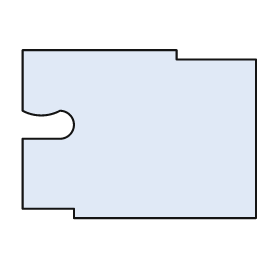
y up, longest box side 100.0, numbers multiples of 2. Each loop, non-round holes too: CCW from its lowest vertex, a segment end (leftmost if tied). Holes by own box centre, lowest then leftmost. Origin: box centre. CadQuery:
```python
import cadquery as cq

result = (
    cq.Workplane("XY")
    .moveTo(-28.0, -36.0)
    .lineTo(50.0, -36.0)
    .lineTo(50.0, 32.0)
    .lineTo(16.0, 32.0)
    .lineTo(16.0, 36.0)
    .lineTo(-50.0, 36.0)
    .lineTo(-50.0, 10.0)
    .threePointArc((-42.0, 8.0), (-34.0, 10.0))
    .threePointArc((-28.0, 4.0), (-34.0, -2.0))
    .lineTo(-50.0, -2.0)
    .lineTo(-50.0, -32.0)
    .lineTo(-28.0, -32.0)
    .close()
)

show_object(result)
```